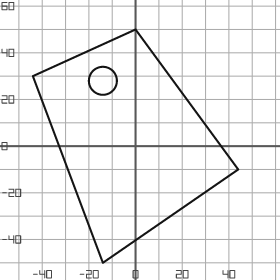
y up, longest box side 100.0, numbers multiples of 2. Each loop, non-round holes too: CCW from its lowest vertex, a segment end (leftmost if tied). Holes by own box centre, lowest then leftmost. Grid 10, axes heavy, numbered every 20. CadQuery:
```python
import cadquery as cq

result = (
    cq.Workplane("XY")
    .moveTo(-14.0, -50.0)
    .lineTo(44.0, -10.0)
    .lineTo(0.0, 50.0)
    .lineTo(-44.0, 30.0)
    .close()
    .moveTo(-14.0, 28.0)
    .circle(6.0)
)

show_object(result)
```